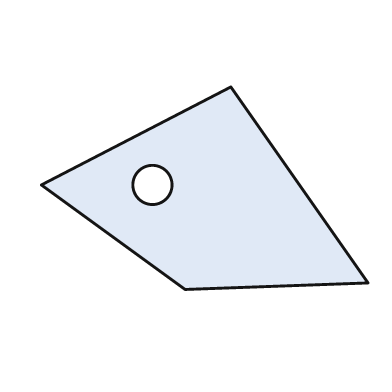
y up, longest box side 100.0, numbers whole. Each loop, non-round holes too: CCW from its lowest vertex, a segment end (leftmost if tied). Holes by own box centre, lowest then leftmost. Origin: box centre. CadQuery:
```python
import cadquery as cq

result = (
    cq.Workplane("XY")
    .moveTo(-6.0, -31.0)
    .lineTo(50.0, -29.0)
    .lineTo(8.0, 31.0)
    .lineTo(-50.0, 1.0)
    .close()
    .moveTo(-16.0, 1.0)
    .circle(6.0)
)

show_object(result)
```